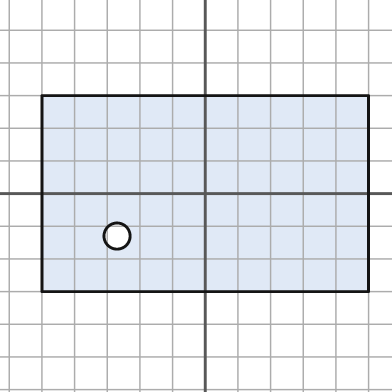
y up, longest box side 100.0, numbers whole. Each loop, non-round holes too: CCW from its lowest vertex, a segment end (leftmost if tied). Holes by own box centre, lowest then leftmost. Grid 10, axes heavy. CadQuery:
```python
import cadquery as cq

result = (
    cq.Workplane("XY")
    .moveTo(-50.0, -30.0)
    .lineTo(50.0, -30.0)
    .lineTo(50.0, 30.0)
    .lineTo(-50.0, 30.0)
    .close()
    .moveTo(-27.0, -13.0)
    .circle(4.0)
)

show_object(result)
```